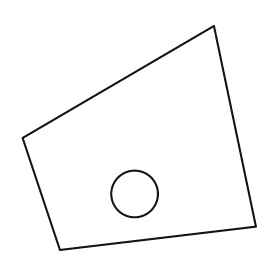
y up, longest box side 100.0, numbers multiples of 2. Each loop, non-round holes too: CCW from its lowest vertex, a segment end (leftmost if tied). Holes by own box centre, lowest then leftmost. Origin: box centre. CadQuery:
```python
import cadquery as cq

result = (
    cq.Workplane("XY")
    .moveTo(-34.0, -48.0)
    .lineTo(50.0, -38.0)
    .lineTo(32.0, 48.0)
    .lineTo(-50.0, 0.0)
    .close()
    .moveTo(-2.0, -24.0)
    .circle(10.0)
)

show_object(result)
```